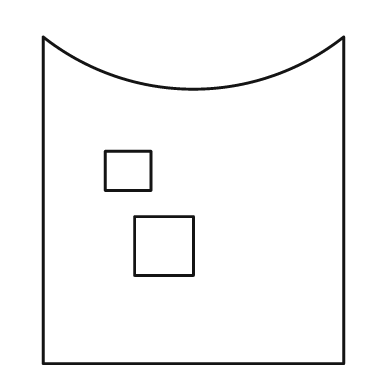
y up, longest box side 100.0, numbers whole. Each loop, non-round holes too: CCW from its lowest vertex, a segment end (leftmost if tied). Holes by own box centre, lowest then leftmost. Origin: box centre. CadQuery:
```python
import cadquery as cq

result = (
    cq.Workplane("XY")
    .moveTo(-46.0, -50.0)
    .lineTo(46.0, -50.0)
    .lineTo(46.0, 50.0)
    .threePointArc((0.0, 34.0), (-46.0, 50.0))
    .close()
    .moveTo(-18.0, -23.0)
    .lineTo(0.0, -23.0)
    .lineTo(0.0, -5.0)
    .lineTo(-18.0, -5.0)
    .close()
    .moveTo(-27.0, 3.0)
    .lineTo(-13.0, 3.0)
    .lineTo(-13.0, 15.0)
    .lineTo(-27.0, 15.0)
    .close()
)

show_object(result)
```